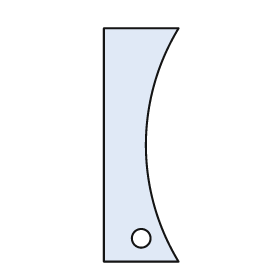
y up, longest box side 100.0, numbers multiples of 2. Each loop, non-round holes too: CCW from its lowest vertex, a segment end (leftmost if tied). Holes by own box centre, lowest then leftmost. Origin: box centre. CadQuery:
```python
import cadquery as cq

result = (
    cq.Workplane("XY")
    .moveTo(-16.0, -50.0)
    .lineTo(16.0, -50.0)
    .threePointArc((2.0, 0.0), (16.0, 50.0))
    .lineTo(-16.0, 50.0)
    .close()
    .moveTo(0.0, -40.0)
    .circle(4.0)
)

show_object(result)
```